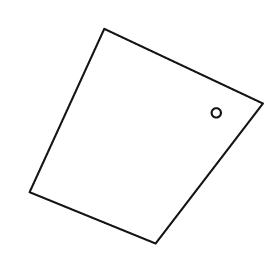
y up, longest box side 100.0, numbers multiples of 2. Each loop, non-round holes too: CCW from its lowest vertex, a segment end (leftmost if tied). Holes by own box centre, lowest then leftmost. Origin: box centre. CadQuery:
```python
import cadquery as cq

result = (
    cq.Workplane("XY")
    .moveTo(4.0, -46.0)
    .lineTo(50.0, 14.0)
    .lineTo(-18.0, 46.0)
    .lineTo(-50.0, -24.0)
    .close()
    .moveTo(30.0, 10.0)
    .circle(2.0)
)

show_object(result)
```